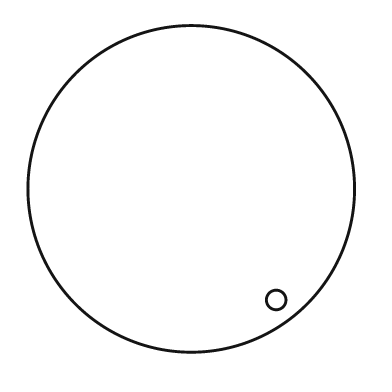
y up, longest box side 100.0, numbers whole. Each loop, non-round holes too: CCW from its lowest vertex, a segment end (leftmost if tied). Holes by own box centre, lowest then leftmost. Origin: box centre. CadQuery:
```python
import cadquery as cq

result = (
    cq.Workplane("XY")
    .moveTo(0.0, 0.0)
    .circle(50.0)
    .moveTo(26.0, -34.0)
    .circle(3.0)
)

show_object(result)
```